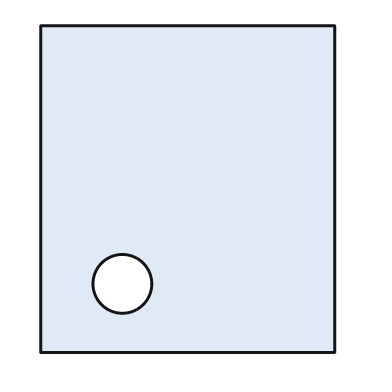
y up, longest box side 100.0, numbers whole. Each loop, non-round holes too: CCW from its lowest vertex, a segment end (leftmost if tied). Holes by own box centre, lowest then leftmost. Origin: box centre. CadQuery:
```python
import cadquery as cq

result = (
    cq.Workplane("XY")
    .moveTo(-45.0, -50.0)
    .lineTo(45.0, -50.0)
    .lineTo(45.0, 50.0)
    .lineTo(-45.0, 50.0)
    .close()
    .moveTo(-20.0, -29.0)
    .circle(9.0)
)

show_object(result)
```